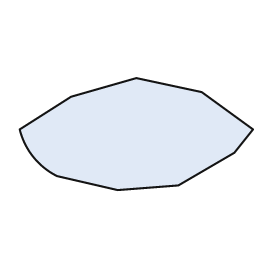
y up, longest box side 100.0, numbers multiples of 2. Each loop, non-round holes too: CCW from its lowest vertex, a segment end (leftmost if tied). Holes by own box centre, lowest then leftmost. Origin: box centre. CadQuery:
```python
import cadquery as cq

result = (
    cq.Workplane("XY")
    .moveTo(-8.0, -24.0)
    .lineTo(18.0, -22.0)
    .lineTo(42.0, -8.0)
    .lineTo(50.0, 2.0)
    .lineTo(28.0, 18.0)
    .lineTo(0.0, 24.0)
    .lineTo(-28.0, 16.0)
    .lineTo(-50.0, 2.0)
    .threePointArc((-44.0, -10.0), (-34.0, -18.0))
    .close()
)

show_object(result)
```